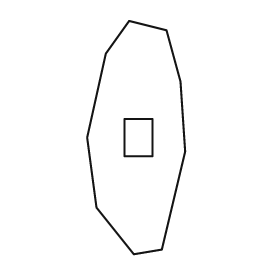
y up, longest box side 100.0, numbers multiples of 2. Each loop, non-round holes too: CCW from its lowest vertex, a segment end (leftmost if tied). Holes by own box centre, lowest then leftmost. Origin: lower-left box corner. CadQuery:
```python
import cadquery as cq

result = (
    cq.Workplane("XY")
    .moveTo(20.0, 0.0)
    .lineTo(32.0, 2.0)
    .lineTo(42.0, 44.0)
    .lineTo(40.0, 74.0)
    .lineTo(34.0, 96.0)
    .lineTo(18.0, 100.0)
    .lineTo(8.0, 86.0)
    .lineTo(0.0, 50.0)
    .lineTo(4.0, 20.0)
    .close()
    .moveTo(16.0, 42.0)
    .lineTo(28.0, 42.0)
    .lineTo(28.0, 58.0)
    .lineTo(16.0, 58.0)
    .close()
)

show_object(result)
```